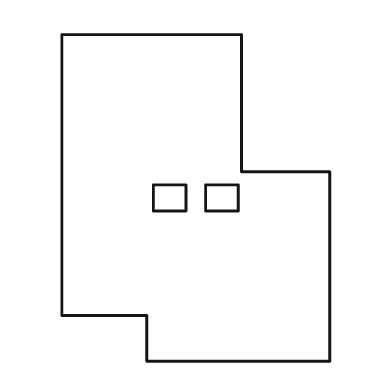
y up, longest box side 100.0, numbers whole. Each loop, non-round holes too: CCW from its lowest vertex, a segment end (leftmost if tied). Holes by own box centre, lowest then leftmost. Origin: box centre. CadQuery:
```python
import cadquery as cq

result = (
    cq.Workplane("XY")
    .moveTo(-15.0, -50.0)
    .lineTo(41.0, -50.0)
    .lineTo(41.0, 8.0)
    .lineTo(14.0, 8.0)
    .lineTo(14.0, 50.0)
    .lineTo(-41.0, 50.0)
    .lineTo(-41.0, -36.0)
    .lineTo(-15.0, -36.0)
    .close()
    .moveTo(-13.0, -4.0)
    .lineTo(-3.0, -4.0)
    .lineTo(-3.0, 4.0)
    .lineTo(-13.0, 4.0)
    .close()
    .moveTo(3.0, -4.0)
    .lineTo(13.0, -4.0)
    .lineTo(13.0, 4.0)
    .lineTo(3.0, 4.0)
    .close()
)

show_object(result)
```